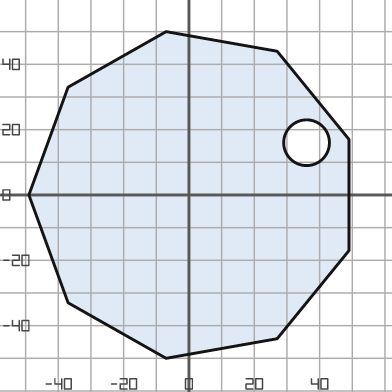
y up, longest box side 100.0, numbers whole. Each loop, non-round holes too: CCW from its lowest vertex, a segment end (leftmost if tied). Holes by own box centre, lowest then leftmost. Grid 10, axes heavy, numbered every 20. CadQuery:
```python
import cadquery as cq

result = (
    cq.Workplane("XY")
    .moveTo(-7.0, -50.0)
    .lineTo(27.0, -44.0)
    .lineTo(49.0, -17.0)
    .lineTo(49.0, 17.0)
    .lineTo(27.0, 44.0)
    .lineTo(-7.0, 50.0)
    .lineTo(-37.0, 33.0)
    .lineTo(-49.0, 0.0)
    .lineTo(-37.0, -33.0)
    .close()
    .moveTo(36.0, 16.0)
    .circle(7.0)
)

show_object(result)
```